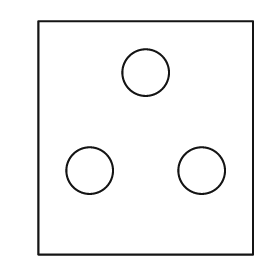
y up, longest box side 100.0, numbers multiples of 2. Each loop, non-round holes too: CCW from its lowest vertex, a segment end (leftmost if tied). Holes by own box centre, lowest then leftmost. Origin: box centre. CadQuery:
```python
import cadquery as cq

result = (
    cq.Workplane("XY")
    .moveTo(-46.0, -50.0)
    .lineTo(46.0, -50.0)
    .lineTo(46.0, 50.0)
    .lineTo(-46.0, 50.0)
    .close()
    .moveTo(-24.0, -14.0)
    .circle(10.0)
    .moveTo(24.0, -14.0)
    .circle(10.0)
    .moveTo(0.0, 28.0)
    .circle(10.0)
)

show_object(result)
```